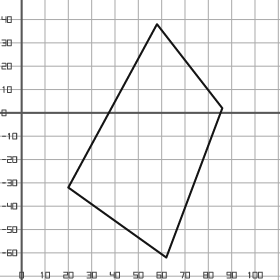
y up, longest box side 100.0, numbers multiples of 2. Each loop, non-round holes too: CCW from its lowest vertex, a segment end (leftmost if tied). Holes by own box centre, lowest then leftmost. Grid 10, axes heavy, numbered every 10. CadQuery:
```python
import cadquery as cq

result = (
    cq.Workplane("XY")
    .moveTo(62.0, -62.0)
    .lineTo(86.0, 2.0)
    .lineTo(58.0, 38.0)
    .lineTo(20.0, -32.0)
    .close()
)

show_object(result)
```